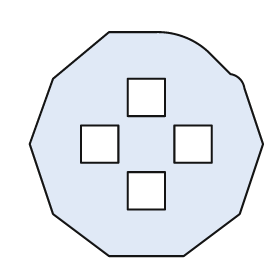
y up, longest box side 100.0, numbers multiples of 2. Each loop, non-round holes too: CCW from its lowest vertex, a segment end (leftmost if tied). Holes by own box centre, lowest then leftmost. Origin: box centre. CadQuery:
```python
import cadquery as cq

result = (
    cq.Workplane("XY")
    .moveTo(-16.0, -48.0)
    .lineTo(16.0, -48.0)
    .lineTo(40.0, -30.0)
    .lineTo(50.0, 0.0)
    .lineTo(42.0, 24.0)
    .threePointArc((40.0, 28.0), (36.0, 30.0))
    .lineTo(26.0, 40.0)
    .threePointArc((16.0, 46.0), (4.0, 48.0))
    .lineTo(-16.0, 48.0)
    .lineTo(-40.0, 28.0)
    .lineTo(-50.0, 0.0)
    .lineTo(-40.0, -30.0)
    .close()
    .moveTo(-8.0, -28.0)
    .lineTo(8.0, -28.0)
    .lineTo(8.0, -12.0)
    .lineTo(-8.0, -12.0)
    .close()
    .moveTo(-28.0, -8.0)
    .lineTo(-12.0, -8.0)
    .lineTo(-12.0, 8.0)
    .lineTo(-28.0, 8.0)
    .close()
    .moveTo(12.0, -8.0)
    .lineTo(28.0, -8.0)
    .lineTo(28.0, 8.0)
    .lineTo(12.0, 8.0)
    .close()
    .moveTo(-8.0, 12.0)
    .lineTo(8.0, 12.0)
    .lineTo(8.0, 28.0)
    .lineTo(-8.0, 28.0)
    .close()
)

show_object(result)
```